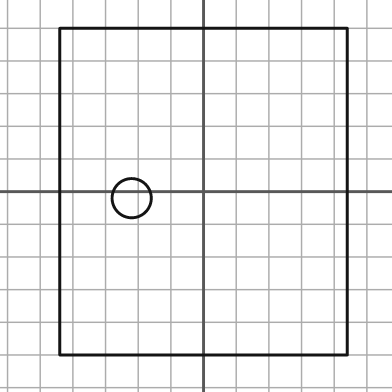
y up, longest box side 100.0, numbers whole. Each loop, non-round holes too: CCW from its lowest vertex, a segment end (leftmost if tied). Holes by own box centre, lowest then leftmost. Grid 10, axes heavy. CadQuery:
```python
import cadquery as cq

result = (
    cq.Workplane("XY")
    .moveTo(-44.0, -50.0)
    .lineTo(44.0, -50.0)
    .lineTo(44.0, 50.0)
    .lineTo(-44.0, 50.0)
    .close()
    .moveTo(-22.0, -2.0)
    .circle(6.0)
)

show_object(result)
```